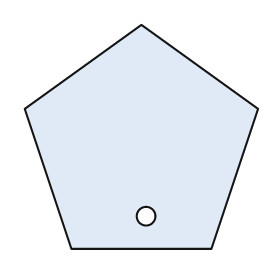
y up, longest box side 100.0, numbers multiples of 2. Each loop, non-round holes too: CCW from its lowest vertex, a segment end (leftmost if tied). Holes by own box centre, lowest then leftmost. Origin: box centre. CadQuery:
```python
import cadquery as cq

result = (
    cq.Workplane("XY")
    .moveTo(-30.0, -48.0)
    .lineTo(30.0, -48.0)
    .lineTo(50.0, 12.0)
    .lineTo(0.0, 48.0)
    .lineTo(-50.0, 12.0)
    .close()
    .moveTo(2.0, -34.0)
    .circle(4.0)
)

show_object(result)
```